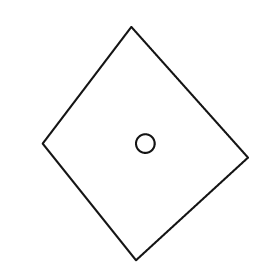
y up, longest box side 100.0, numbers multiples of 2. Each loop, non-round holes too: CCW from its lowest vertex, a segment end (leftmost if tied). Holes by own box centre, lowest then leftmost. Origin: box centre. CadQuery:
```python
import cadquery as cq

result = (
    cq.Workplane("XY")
    .moveTo(-4.0, -50.0)
    .lineTo(44.0, -6.0)
    .lineTo(-6.0, 50.0)
    .lineTo(-44.0, 0.0)
    .close()
    .moveTo(0.0, 0.0)
    .circle(4.0)
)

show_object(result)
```